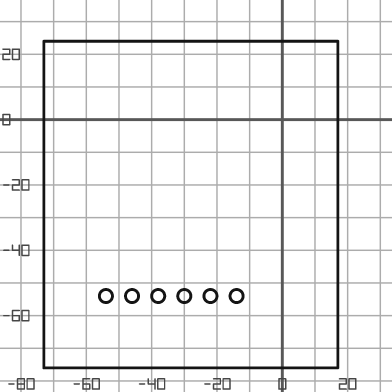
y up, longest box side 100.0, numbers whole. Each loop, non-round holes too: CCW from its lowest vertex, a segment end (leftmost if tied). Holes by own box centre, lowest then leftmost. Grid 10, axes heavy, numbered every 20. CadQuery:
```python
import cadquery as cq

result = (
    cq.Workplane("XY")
    .moveTo(-73.0, -76.0)
    .lineTo(17.0, -76.0)
    .lineTo(17.0, 24.0)
    .lineTo(-73.0, 24.0)
    .close()
    .moveTo(-54.0, -54.0)
    .circle(2.0)
    .moveTo(-46.0, -54.0)
    .circle(2.0)
    .moveTo(-38.0, -54.0)
    .circle(2.0)
    .moveTo(-30.0, -54.0)
    .circle(2.0)
    .moveTo(-22.0, -54.0)
    .circle(2.0)
    .moveTo(-14.0, -54.0)
    .circle(2.0)
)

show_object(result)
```